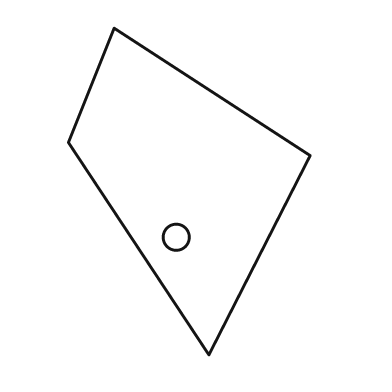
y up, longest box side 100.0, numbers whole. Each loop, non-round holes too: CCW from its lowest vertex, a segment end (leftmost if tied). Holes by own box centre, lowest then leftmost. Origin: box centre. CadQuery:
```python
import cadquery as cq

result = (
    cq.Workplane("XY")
    .moveTo(6.0, -50.0)
    .lineTo(37.0, 11.0)
    .lineTo(-23.0, 50.0)
    .lineTo(-37.0, 15.0)
    .close()
    .moveTo(-4.0, -14.0)
    .circle(4.0)
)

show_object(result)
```